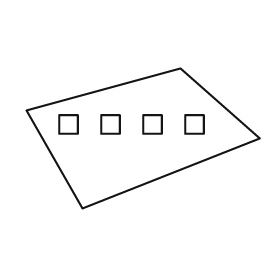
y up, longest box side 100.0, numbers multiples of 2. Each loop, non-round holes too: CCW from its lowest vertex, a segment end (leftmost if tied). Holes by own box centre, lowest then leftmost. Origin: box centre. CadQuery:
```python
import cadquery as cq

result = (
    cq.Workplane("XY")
    .moveTo(-26.0, -30.0)
    .lineTo(50.0, 0.0)
    .lineTo(16.0, 30.0)
    .lineTo(-50.0, 12.0)
    .close()
    .moveTo(-36.0, 2.0)
    .lineTo(-28.0, 2.0)
    .lineTo(-28.0, 10.0)
    .lineTo(-36.0, 10.0)
    .close()
    .moveTo(-18.0, 2.0)
    .lineTo(-10.0, 2.0)
    .lineTo(-10.0, 10.0)
    .lineTo(-18.0, 10.0)
    .close()
    .moveTo(0.0, 2.0)
    .lineTo(8.0, 2.0)
    .lineTo(8.0, 10.0)
    .lineTo(0.0, 10.0)
    .close()
    .moveTo(18.0, 2.0)
    .lineTo(26.0, 2.0)
    .lineTo(26.0, 10.0)
    .lineTo(18.0, 10.0)
    .close()
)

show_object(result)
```